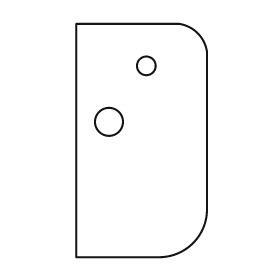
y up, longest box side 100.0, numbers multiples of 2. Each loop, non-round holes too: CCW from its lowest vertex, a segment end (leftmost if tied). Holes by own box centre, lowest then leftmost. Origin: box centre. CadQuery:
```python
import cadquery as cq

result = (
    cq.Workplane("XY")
    .moveTo(-28.0, -50.0)
    .lineTo(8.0, -50.0)
    .threePointArc((22.0, -44.0), (28.0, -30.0))
    .lineTo(28.0, 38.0)
    .threePointArc((24.0, 46.0), (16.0, 50.0))
    .lineTo(-28.0, 50.0)
    .close()
    .moveTo(-14.0, 8.0)
    .circle(6.0)
    .moveTo(2.0, 32.0)
    .circle(4.0)
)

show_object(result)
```